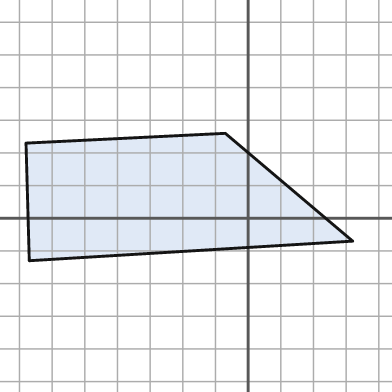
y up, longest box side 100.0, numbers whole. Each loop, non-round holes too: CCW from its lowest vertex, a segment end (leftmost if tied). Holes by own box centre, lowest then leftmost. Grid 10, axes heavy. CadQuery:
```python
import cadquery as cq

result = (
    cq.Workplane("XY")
    .moveTo(-67.0, -13.0)
    .lineTo(32.0, -7.0)
    .lineTo(-7.0, 26.0)
    .lineTo(-68.0, 23.0)
    .close()
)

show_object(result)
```